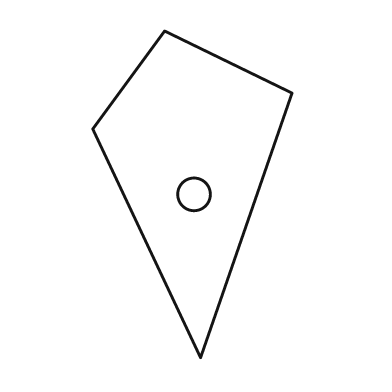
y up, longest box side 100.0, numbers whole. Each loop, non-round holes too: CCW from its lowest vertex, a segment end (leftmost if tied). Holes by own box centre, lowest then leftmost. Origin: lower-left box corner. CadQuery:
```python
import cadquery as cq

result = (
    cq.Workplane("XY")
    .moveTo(33.0, 0.0)
    .lineTo(61.0, 81.0)
    .lineTo(22.0, 100.0)
    .lineTo(0.0, 70.0)
    .close()
    .moveTo(31.0, 50.0)
    .circle(5.0)
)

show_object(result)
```